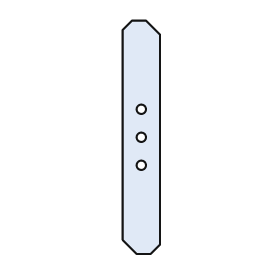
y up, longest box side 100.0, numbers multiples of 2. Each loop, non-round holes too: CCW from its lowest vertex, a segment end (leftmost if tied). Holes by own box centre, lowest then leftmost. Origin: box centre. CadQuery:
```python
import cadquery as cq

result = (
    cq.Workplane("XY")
    .moveTo(-2.0, -50.0)
    .lineTo(4.0, -50.0)
    .lineTo(8.0, -46.0)
    .lineTo(8.0, 44.0)
    .lineTo(2.0, 50.0)
    .lineTo(-4.0, 50.0)
    .lineTo(-8.0, 46.0)
    .lineTo(-8.0, -44.0)
    .close()
    .moveTo(0.0, -12.0)
    .circle(2.0)
    .moveTo(0.0, 0.0)
    .circle(2.0)
    .moveTo(0.0, 12.0)
    .circle(2.0)
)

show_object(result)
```